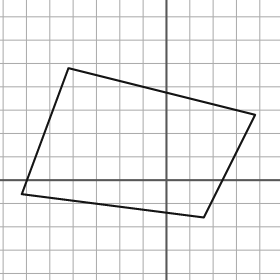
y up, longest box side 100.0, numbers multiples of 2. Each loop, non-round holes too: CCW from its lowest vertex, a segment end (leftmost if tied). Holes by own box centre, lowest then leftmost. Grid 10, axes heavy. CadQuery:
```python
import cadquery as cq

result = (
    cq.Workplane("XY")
    .moveTo(16.0, -16.0)
    .lineTo(38.0, 28.0)
    .lineTo(-42.0, 48.0)
    .lineTo(-62.0, -6.0)
    .close()
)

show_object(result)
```